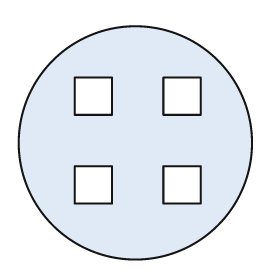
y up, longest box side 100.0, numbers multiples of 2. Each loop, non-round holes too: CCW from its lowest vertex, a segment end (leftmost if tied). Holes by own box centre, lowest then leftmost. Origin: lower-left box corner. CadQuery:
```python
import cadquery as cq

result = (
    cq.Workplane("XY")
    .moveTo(50.0, 50.0)
    .circle(50.0)
    .moveTo(24.0, 24.0)
    .lineTo(40.0, 24.0)
    .lineTo(40.0, 40.0)
    .lineTo(24.0, 40.0)
    .close()
    .moveTo(62.0, 24.0)
    .lineTo(78.0, 24.0)
    .lineTo(78.0, 40.0)
    .lineTo(62.0, 40.0)
    .close()
    .moveTo(24.0, 62.0)
    .lineTo(40.0, 62.0)
    .lineTo(40.0, 78.0)
    .lineTo(24.0, 78.0)
    .close()
    .moveTo(62.0, 62.0)
    .lineTo(78.0, 62.0)
    .lineTo(78.0, 78.0)
    .lineTo(62.0, 78.0)
    .close()
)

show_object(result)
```